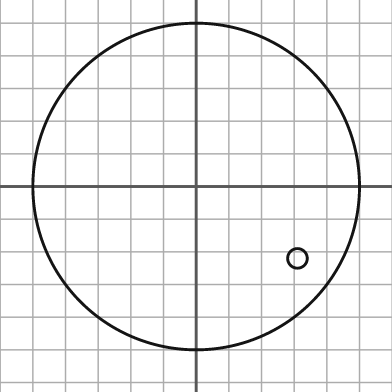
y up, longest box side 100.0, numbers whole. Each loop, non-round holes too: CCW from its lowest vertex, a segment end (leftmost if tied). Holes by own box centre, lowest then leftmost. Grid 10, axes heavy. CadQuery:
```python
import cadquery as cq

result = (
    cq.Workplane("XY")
    .moveTo(0.0, 0.0)
    .circle(50.0)
    .moveTo(31.0, -22.0)
    .circle(3.0)
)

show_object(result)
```